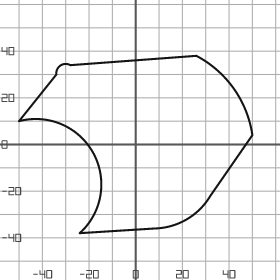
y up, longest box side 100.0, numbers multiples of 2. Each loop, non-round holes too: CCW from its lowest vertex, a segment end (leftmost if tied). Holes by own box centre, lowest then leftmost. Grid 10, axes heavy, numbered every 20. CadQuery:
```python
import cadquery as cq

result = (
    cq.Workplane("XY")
    .moveTo(-24.0, -38.0)
    .lineTo(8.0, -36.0)
    .threePointArc((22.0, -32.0), (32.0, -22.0))
    .lineTo(50.0, 4.0)
    .threePointArc((42.0, 24.0), (26.0, 38.0))
    .lineTo(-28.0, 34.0)
    .threePointArc((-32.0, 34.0), (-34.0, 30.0))
    .lineTo(-50.0, 10.0)
    .threePointArc((-18.0, -4.0), (-24.0, -38.0))
    .close()
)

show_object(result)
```